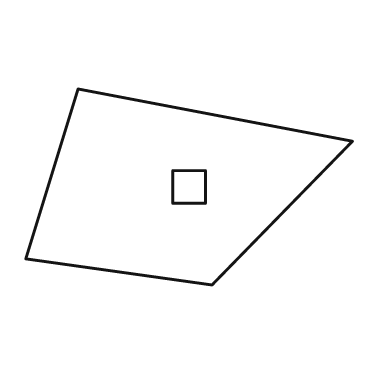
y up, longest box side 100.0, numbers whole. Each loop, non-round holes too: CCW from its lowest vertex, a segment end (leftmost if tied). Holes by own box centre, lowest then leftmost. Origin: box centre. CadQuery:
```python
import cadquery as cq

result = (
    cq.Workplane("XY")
    .moveTo(7.0, -30.0)
    .lineTo(50.0, 14.0)
    .lineTo(-34.0, 30.0)
    .lineTo(-50.0, -22.0)
    .close()
    .moveTo(-5.0, -5.0)
    .lineTo(5.0, -5.0)
    .lineTo(5.0, 5.0)
    .lineTo(-5.0, 5.0)
    .close()
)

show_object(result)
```